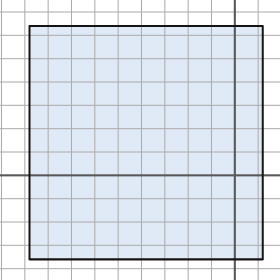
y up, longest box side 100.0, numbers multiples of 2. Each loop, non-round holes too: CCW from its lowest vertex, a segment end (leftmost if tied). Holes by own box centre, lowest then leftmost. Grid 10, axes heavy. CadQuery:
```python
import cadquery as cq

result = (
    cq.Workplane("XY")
    .moveTo(-88.0, -36.0)
    .lineTo(12.0, -36.0)
    .lineTo(12.0, 64.0)
    .lineTo(-88.0, 64.0)
    .close()
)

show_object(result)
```